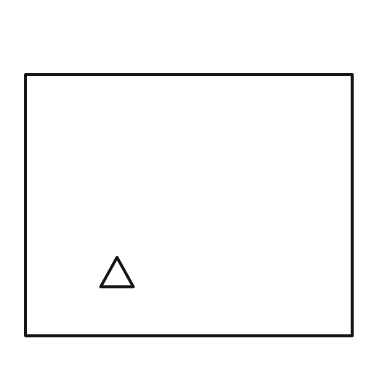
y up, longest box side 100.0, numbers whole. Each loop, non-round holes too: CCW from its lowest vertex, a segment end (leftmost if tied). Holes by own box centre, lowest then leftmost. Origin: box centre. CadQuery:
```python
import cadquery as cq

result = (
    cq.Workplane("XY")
    .moveTo(-50.0, -40.0)
    .lineTo(50.0, -40.0)
    .lineTo(50.0, 40.0)
    .lineTo(-50.0, 40.0)
    .close()
    .moveTo(-27.0, -25.0)
    .lineTo(-17.0, -25.0)
    .lineTo(-22.0, -16.0)
    .close()
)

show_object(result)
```